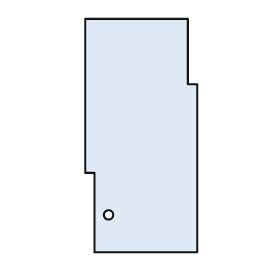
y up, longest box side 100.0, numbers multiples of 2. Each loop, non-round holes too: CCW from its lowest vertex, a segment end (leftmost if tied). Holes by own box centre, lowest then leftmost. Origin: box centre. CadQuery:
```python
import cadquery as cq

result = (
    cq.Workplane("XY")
    .moveTo(-20.0, -50.0)
    .lineTo(24.0, -50.0)
    .lineTo(24.0, 22.0)
    .lineTo(20.0, 22.0)
    .lineTo(20.0, 50.0)
    .lineTo(-24.0, 50.0)
    .lineTo(-24.0, -16.0)
    .lineTo(-20.0, -16.0)
    .close()
    .moveTo(-14.0, -34.0)
    .circle(2.0)
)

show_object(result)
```